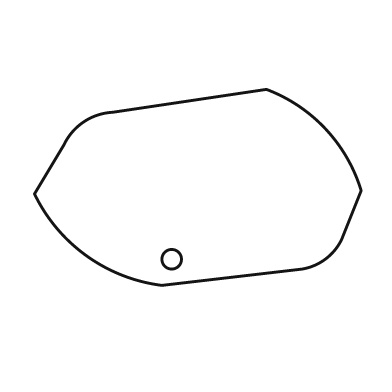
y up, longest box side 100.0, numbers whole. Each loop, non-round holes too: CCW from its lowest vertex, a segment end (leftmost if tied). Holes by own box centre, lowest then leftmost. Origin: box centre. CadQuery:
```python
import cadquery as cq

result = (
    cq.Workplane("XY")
    .moveTo(-11.0, -30.0)
    .lineTo(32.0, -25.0)
    .threePointArc((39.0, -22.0), (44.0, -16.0))
    .lineTo(50.0, -1.0)
    .threePointArc((39.0, 18.0), (21.0, 30.0))
    .lineTo(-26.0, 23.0)
    .threePointArc((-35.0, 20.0), (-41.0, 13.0))
    .lineTo(-50.0, -2.0)
    .threePointArc((-34.0, -21.0), (-11.0, -30.0))
    .close()
    .moveTo(-8.0, -22.0)
    .circle(3.0)
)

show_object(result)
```